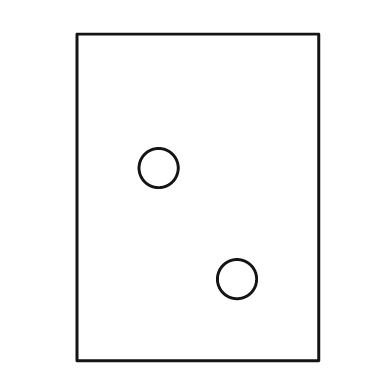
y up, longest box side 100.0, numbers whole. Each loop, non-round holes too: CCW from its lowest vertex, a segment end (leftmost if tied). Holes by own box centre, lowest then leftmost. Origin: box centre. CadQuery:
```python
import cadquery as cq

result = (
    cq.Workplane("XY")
    .moveTo(-37.0, -50.0)
    .lineTo(37.0, -50.0)
    .lineTo(37.0, 50.0)
    .lineTo(-37.0, 50.0)
    .close()
    .moveTo(12.0, -25.0)
    .circle(6.0)
    .moveTo(-12.0, 9.0)
    .circle(6.0)
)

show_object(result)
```